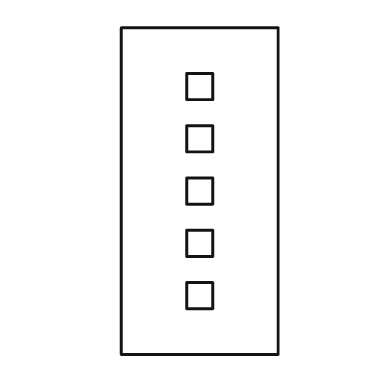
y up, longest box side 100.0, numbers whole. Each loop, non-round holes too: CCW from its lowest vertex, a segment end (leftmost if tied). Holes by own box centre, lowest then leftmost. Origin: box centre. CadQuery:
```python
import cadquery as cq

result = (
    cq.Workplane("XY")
    .moveTo(-24.0, -50.0)
    .lineTo(24.0, -50.0)
    .lineTo(24.0, 50.0)
    .lineTo(-24.0, 50.0)
    .close()
    .moveTo(-4.0, -36.0)
    .lineTo(4.0, -36.0)
    .lineTo(4.0, -28.0)
    .lineTo(-4.0, -28.0)
    .close()
    .moveTo(-4.0, -20.0)
    .lineTo(4.0, -20.0)
    .lineTo(4.0, -12.0)
    .lineTo(-4.0, -12.0)
    .close()
    .moveTo(-4.0, -4.0)
    .lineTo(4.0, -4.0)
    .lineTo(4.0, 4.0)
    .lineTo(-4.0, 4.0)
    .close()
    .moveTo(-4.0, 12.0)
    .lineTo(4.0, 12.0)
    .lineTo(4.0, 20.0)
    .lineTo(-4.0, 20.0)
    .close()
    .moveTo(-4.0, 28.0)
    .lineTo(4.0, 28.0)
    .lineTo(4.0, 36.0)
    .lineTo(-4.0, 36.0)
    .close()
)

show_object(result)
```